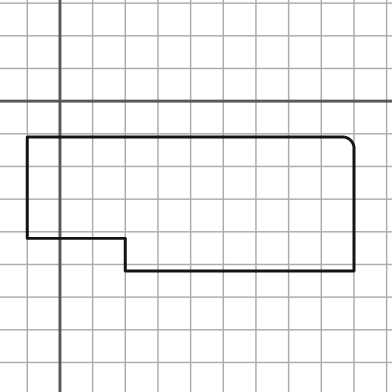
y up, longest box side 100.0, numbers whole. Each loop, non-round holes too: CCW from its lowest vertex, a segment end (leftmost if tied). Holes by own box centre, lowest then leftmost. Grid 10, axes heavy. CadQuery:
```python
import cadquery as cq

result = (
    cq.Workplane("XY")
    .moveTo(20.0, -52.0)
    .lineTo(90.0, -52.0)
    .lineTo(90.0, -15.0)
    .threePointArc((89.0, -12.0), (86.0, -11.0))
    .lineTo(-10.0, -11.0)
    .lineTo(-10.0, -42.0)
    .lineTo(20.0, -42.0)
    .close()
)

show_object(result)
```